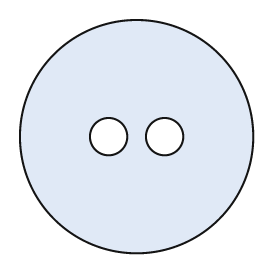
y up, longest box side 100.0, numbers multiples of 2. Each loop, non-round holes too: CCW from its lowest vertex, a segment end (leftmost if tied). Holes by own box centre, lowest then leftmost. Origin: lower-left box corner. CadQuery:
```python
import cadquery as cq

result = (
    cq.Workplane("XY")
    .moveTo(50.0, 50.0)
    .circle(50.0)
    .moveTo(38.0, 50.0)
    .circle(8.0)
    .moveTo(62.0, 50.0)
    .circle(8.0)
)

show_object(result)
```